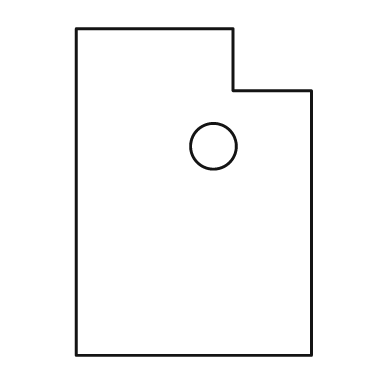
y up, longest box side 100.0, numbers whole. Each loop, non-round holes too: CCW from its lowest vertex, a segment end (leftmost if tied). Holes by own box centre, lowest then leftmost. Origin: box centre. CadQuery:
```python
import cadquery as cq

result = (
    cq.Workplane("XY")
    .moveTo(-36.0, -50.0)
    .lineTo(36.0, -50.0)
    .lineTo(36.0, 31.0)
    .lineTo(12.0, 31.0)
    .lineTo(12.0, 50.0)
    .lineTo(-36.0, 50.0)
    .close()
    .moveTo(6.0, 14.0)
    .circle(7.0)
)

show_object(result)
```